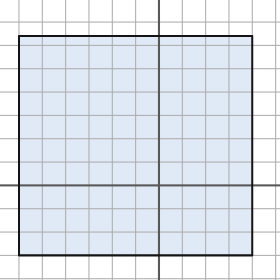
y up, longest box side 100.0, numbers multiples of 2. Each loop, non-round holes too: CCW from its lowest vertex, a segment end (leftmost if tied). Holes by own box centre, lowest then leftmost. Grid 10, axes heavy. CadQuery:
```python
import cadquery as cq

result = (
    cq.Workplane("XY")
    .moveTo(-60.0, -30.0)
    .lineTo(40.0, -30.0)
    .lineTo(40.0, 64.0)
    .lineTo(-60.0, 64.0)
    .close()
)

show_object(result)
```